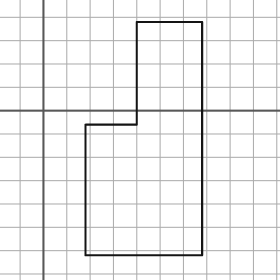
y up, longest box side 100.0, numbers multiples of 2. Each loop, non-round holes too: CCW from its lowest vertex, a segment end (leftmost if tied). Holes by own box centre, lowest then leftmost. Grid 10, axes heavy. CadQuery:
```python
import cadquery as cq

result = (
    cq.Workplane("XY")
    .moveTo(18.0, -62.0)
    .lineTo(68.0, -62.0)
    .lineTo(68.0, 38.0)
    .lineTo(40.0, 38.0)
    .lineTo(40.0, -6.0)
    .lineTo(18.0, -6.0)
    .close()
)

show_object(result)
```